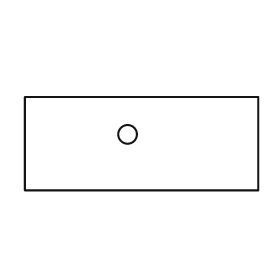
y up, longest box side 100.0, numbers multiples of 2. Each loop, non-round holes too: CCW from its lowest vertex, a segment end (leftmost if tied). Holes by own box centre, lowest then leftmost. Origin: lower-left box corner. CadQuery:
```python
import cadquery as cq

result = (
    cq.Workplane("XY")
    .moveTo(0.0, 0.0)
    .lineTo(100.0, 0.0)
    .lineTo(100.0, 40.0)
    .lineTo(0.0, 40.0)
    .close()
    .moveTo(44.0, 24.0)
    .circle(4.0)
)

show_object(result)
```